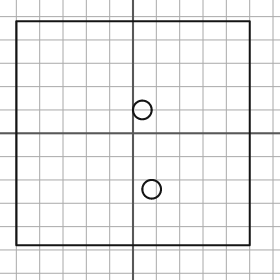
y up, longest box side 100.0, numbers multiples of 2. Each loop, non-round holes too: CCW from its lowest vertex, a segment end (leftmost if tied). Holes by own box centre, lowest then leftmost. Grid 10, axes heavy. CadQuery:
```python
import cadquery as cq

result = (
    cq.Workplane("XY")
    .moveTo(-50.0, -48.0)
    .lineTo(50.0, -48.0)
    .lineTo(50.0, 48.0)
    .lineTo(-50.0, 48.0)
    .close()
    .moveTo(8.0, -24.0)
    .circle(4.0)
    .moveTo(4.0, 10.0)
    .circle(4.0)
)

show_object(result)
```